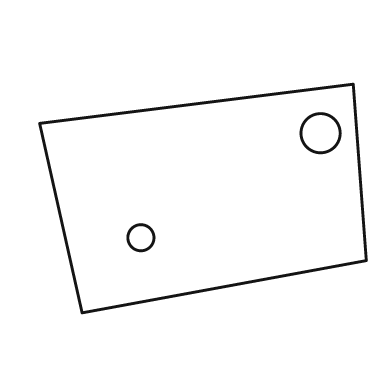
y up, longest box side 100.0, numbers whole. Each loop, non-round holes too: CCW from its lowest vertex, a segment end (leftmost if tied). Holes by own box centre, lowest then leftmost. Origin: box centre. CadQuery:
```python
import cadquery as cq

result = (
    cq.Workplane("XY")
    .moveTo(-37.0, -35.0)
    .lineTo(50.0, -19.0)
    .lineTo(46.0, 35.0)
    .lineTo(-50.0, 23.0)
    .close()
    .moveTo(-19.0, -12.0)
    .circle(4.0)
    .moveTo(36.0, 20.0)
    .circle(6.0)
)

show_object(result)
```